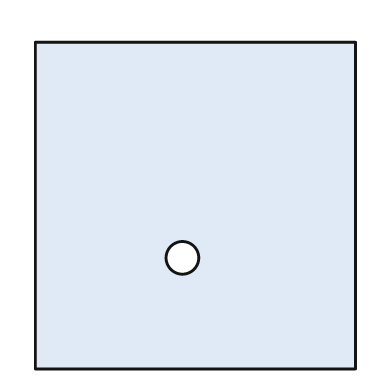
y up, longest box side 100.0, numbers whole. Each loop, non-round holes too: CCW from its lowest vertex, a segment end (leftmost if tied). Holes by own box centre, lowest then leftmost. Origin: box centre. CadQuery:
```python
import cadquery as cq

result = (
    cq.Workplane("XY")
    .moveTo(-49.0, -50.0)
    .lineTo(49.0, -50.0)
    .lineTo(49.0, 50.0)
    .lineTo(-49.0, 50.0)
    .close()
    .moveTo(-4.0, -16.0)
    .circle(5.0)
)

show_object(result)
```